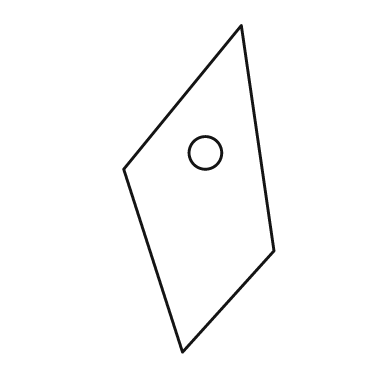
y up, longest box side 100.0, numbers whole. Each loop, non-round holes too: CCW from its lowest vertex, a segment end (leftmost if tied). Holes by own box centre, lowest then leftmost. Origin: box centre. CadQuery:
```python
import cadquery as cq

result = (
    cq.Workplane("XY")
    .moveTo(-5.0, -50.0)
    .lineTo(23.0, -19.0)
    .lineTo(13.0, 50.0)
    .lineTo(-23.0, 6.0)
    .close()
    .moveTo(2.0, 11.0)
    .circle(5.0)
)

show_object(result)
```